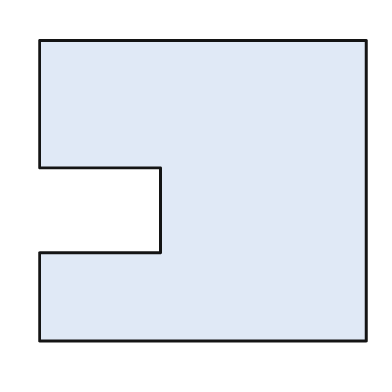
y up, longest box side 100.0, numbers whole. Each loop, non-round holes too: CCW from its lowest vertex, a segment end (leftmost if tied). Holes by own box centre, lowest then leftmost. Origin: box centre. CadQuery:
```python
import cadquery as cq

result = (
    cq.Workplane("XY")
    .moveTo(-50.0, -46.0)
    .lineTo(50.0, -46.0)
    .lineTo(50.0, 46.0)
    .lineTo(-50.0, 46.0)
    .lineTo(-50.0, 7.0)
    .lineTo(-13.0, 7.0)
    .lineTo(-13.0, -19.0)
    .lineTo(-50.0, -19.0)
    .close()
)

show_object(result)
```